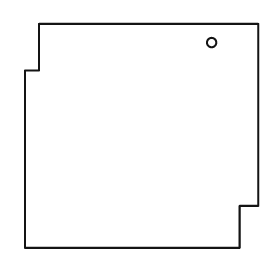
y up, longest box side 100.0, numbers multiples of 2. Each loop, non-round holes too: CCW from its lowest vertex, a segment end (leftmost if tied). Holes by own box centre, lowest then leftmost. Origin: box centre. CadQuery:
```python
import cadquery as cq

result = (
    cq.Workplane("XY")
    .moveTo(-50.0, -48.0)
    .lineTo(42.0, -48.0)
    .lineTo(42.0, -30.0)
    .lineTo(50.0, -30.0)
    .lineTo(50.0, 48.0)
    .lineTo(-44.0, 48.0)
    .lineTo(-44.0, 28.0)
    .lineTo(-50.0, 28.0)
    .close()
    .moveTo(30.0, 40.0)
    .circle(2.0)
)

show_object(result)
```